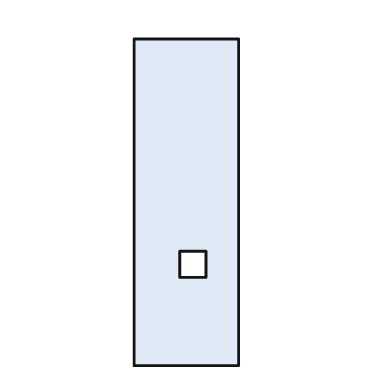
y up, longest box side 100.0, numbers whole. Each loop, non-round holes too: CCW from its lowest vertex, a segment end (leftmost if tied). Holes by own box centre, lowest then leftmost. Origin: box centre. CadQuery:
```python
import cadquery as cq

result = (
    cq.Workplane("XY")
    .moveTo(-16.0, -50.0)
    .lineTo(16.0, -50.0)
    .lineTo(16.0, 50.0)
    .lineTo(-16.0, 50.0)
    .close()
    .moveTo(-2.0, -23.0)
    .lineTo(6.0, -23.0)
    .lineTo(6.0, -15.0)
    .lineTo(-2.0, -15.0)
    .close()
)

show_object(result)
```